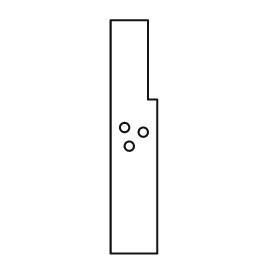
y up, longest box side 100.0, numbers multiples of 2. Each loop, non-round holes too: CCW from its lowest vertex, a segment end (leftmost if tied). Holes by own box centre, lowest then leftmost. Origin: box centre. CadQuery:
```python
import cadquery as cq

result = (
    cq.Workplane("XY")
    .moveTo(-10.0, -50.0)
    .lineTo(10.0, -50.0)
    .lineTo(10.0, 16.0)
    .lineTo(6.0, 16.0)
    .lineTo(6.0, 50.0)
    .lineTo(-10.0, 50.0)
    .close()
    .moveTo(-2.0, -4.0)
    .circle(2.0)
    .moveTo(4.0, 2.0)
    .circle(2.0)
    .moveTo(-4.0, 4.0)
    .circle(2.0)
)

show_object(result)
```